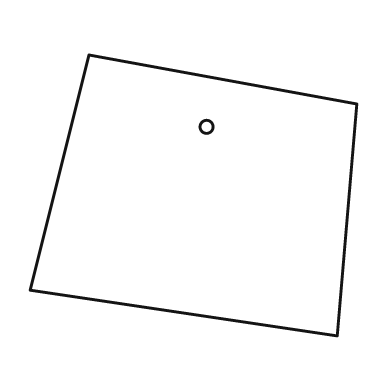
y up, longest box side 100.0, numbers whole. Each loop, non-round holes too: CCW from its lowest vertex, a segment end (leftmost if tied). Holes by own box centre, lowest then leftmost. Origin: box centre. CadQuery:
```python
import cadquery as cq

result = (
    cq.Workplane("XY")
    .moveTo(44.0, -43.0)
    .lineTo(50.0, 28.0)
    .lineTo(-32.0, 43.0)
    .lineTo(-50.0, -29.0)
    .close()
    .moveTo(4.0, 21.0)
    .circle(2.0)
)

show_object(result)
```